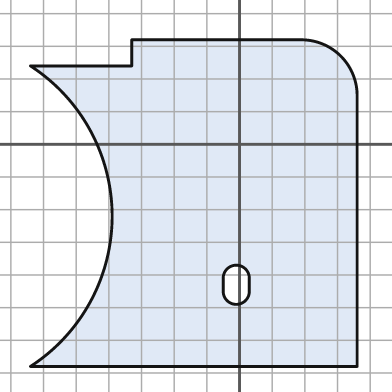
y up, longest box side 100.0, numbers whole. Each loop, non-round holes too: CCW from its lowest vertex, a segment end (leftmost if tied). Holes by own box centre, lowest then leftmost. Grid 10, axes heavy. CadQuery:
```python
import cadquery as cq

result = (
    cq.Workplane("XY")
    .moveTo(-64.0, -68.0)
    .lineTo(36.0, -68.0)
    .lineTo(36.0, 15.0)
    .threePointArc((31.0, 27.0), (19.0, 32.0))
    .lineTo(-33.0, 32.0)
    .lineTo(-33.0, 24.0)
    .lineTo(-64.0, 24.0)
    .threePointArc((-39.0, -22.0), (-64.0, -68.0))
    .close()
    .moveTo(-5.0, -45.0)
    .threePointArc((-1.0, -49.0), (3.0, -45.0))
    .lineTo(3.0, -41.0)
    .threePointArc((-1.0, -37.0), (-5.0, -41.0))
    .close()
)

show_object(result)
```